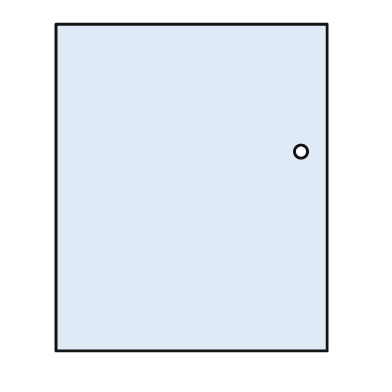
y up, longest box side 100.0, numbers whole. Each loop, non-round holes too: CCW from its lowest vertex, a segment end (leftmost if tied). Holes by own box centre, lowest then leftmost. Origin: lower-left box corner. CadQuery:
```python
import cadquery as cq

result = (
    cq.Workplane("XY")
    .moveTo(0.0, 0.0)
    .lineTo(83.0, 0.0)
    .lineTo(83.0, 100.0)
    .lineTo(0.0, 100.0)
    .close()
    .moveTo(75.0, 61.0)
    .circle(2.0)
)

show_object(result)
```